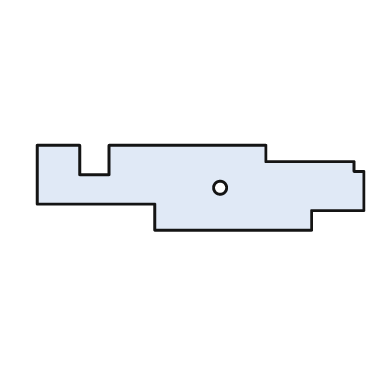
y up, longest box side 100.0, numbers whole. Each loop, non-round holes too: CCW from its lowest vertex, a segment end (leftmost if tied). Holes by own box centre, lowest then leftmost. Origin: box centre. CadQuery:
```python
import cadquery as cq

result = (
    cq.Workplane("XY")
    .moveTo(-14.0, -13.0)
    .lineTo(34.0, -13.0)
    .lineTo(34.0, -7.0)
    .lineTo(50.0, -7.0)
    .lineTo(50.0, 5.0)
    .lineTo(47.0, 5.0)
    .lineTo(47.0, 8.0)
    .lineTo(20.0, 8.0)
    .lineTo(20.0, 13.0)
    .lineTo(-28.0, 13.0)
    .lineTo(-28.0, 4.0)
    .lineTo(-37.0, 4.0)
    .lineTo(-37.0, 13.0)
    .lineTo(-50.0, 13.0)
    .lineTo(-50.0, -5.0)
    .lineTo(-14.0, -5.0)
    .close()
    .moveTo(6.0, 0.0)
    .circle(2.0)
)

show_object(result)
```